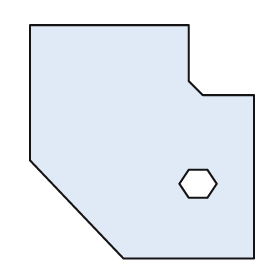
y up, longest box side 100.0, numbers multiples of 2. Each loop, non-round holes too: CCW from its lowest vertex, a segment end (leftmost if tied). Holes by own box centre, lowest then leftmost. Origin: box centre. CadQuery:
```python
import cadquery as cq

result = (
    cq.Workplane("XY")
    .moveTo(-8.0, -50.0)
    .lineTo(48.0, -50.0)
    .lineTo(48.0, 20.0)
    .lineTo(26.0, 20.0)
    .lineTo(20.0, 26.0)
    .lineTo(20.0, 50.0)
    .lineTo(-48.0, 50.0)
    .lineTo(-48.0, -8.0)
    .close()
    .moveTo(20.0, -24.0)
    .lineTo(28.0, -24.0)
    .lineTo(32.0, -18.0)
    .lineTo(28.0, -12.0)
    .lineTo(20.0, -12.0)
    .lineTo(16.0, -18.0)
    .close()
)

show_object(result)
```